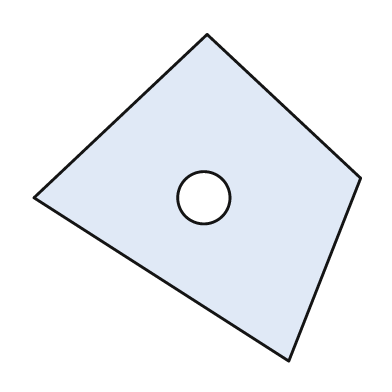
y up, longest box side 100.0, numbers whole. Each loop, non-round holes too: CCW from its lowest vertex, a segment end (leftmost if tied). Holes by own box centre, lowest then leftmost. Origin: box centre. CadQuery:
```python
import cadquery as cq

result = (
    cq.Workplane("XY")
    .moveTo(28.0, -50.0)
    .lineTo(50.0, 6.0)
    .lineTo(3.0, 50.0)
    .lineTo(-50.0, 0.0)
    .close()
    .moveTo(2.0, 0.0)
    .circle(8.0)
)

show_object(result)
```